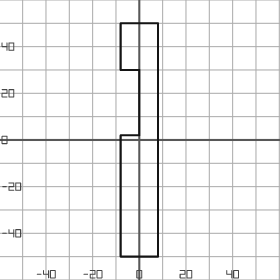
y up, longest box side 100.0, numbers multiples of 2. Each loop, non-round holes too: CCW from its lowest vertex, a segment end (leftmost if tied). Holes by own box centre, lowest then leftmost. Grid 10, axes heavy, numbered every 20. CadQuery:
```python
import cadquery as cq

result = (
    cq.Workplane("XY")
    .moveTo(-8.0, -50.0)
    .lineTo(8.0, -50.0)
    .lineTo(8.0, 50.0)
    .lineTo(-8.0, 50.0)
    .lineTo(-8.0, 30.0)
    .lineTo(0.0, 30.0)
    .lineTo(0.0, 2.0)
    .lineTo(-8.0, 2.0)
    .close()
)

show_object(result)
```